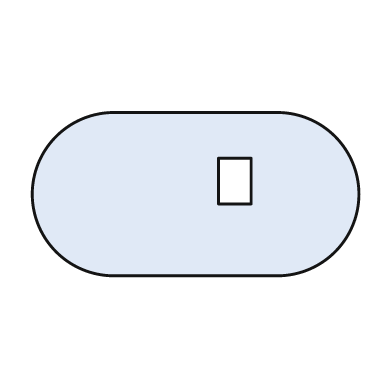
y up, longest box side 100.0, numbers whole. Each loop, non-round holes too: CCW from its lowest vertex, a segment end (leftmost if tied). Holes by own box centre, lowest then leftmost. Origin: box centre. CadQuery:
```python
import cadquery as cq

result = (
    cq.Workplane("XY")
    .moveTo(-25.0, -25.0)
    .lineTo(25.0, -25.0)
    .threePointArc((50.0, 0.0), (25.0, 25.0))
    .lineTo(-25.0, 25.0)
    .threePointArc((-50.0, 0.0), (-25.0, -25.0))
    .close()
    .moveTo(7.0, -3.0)
    .lineTo(17.0, -3.0)
    .lineTo(17.0, 11.0)
    .lineTo(7.0, 11.0)
    .close()
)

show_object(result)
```